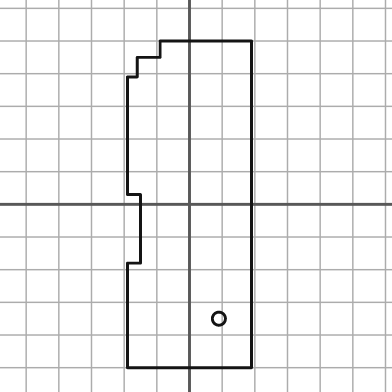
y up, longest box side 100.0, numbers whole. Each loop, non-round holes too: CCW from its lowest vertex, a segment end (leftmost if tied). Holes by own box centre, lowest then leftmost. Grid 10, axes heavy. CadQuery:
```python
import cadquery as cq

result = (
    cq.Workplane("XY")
    .moveTo(-19.0, -50.0)
    .lineTo(19.0, -50.0)
    .lineTo(19.0, 50.0)
    .lineTo(-9.0, 50.0)
    .lineTo(-9.0, 45.0)
    .lineTo(-16.0, 45.0)
    .lineTo(-16.0, 39.0)
    .lineTo(-19.0, 39.0)
    .lineTo(-19.0, 3.0)
    .lineTo(-15.0, 3.0)
    .lineTo(-15.0, -18.0)
    .lineTo(-19.0, -18.0)
    .close()
    .moveTo(9.0, -35.0)
    .circle(2.0)
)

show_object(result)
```